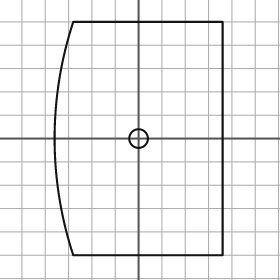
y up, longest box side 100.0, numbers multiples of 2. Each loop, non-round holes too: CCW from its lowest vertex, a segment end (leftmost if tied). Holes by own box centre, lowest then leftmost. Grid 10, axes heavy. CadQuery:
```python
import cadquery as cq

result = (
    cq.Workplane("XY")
    .moveTo(-28.0, -50.0)
    .lineTo(36.0, -50.0)
    .lineTo(36.0, 50.0)
    .lineTo(-28.0, 50.0)
    .threePointArc((-36.0, 0.0), (-28.0, -50.0))
    .close()
    .moveTo(0.0, 0.0)
    .circle(4.0)
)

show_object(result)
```